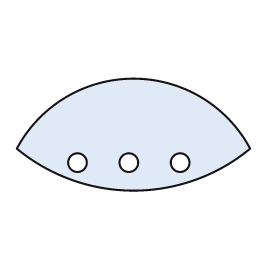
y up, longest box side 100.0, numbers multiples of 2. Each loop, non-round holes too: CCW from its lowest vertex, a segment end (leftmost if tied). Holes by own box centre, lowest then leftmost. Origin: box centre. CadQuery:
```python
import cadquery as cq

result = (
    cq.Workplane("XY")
    .moveTo(-50.0, -6.0)
    .threePointArc((0.0, -24.0), (50.0, -6.0))
    .threePointArc((0.0, 24.0), (-50.0, -6.0))
    .close()
    .moveTo(-24.0, -12.0)
    .circle(4.0)
    .moveTo(-2.0, -12.0)
    .circle(4.0)
    .moveTo(20.0, -12.0)
    .circle(4.0)
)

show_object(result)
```